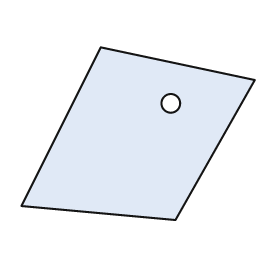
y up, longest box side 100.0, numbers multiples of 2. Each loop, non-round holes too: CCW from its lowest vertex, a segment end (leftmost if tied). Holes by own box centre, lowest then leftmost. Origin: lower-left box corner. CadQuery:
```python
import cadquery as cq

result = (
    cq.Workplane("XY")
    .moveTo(66.0, 0.0)
    .lineTo(100.0, 60.0)
    .lineTo(34.0, 74.0)
    .lineTo(0.0, 6.0)
    .close()
    .moveTo(64.0, 50.0)
    .circle(4.0)
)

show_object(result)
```